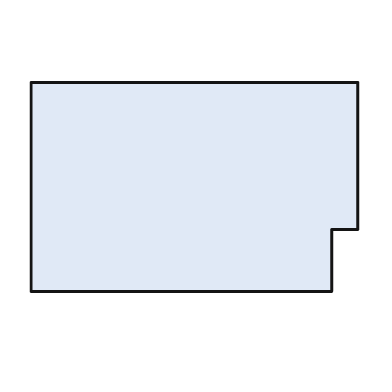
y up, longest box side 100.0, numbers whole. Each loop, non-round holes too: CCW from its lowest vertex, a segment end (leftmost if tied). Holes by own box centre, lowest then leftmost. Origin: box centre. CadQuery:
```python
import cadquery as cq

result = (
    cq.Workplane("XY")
    .moveTo(-50.0, -32.0)
    .lineTo(42.0, -32.0)
    .lineTo(42.0, -13.0)
    .lineTo(50.0, -13.0)
    .lineTo(50.0, 32.0)
    .lineTo(-50.0, 32.0)
    .close()
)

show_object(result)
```